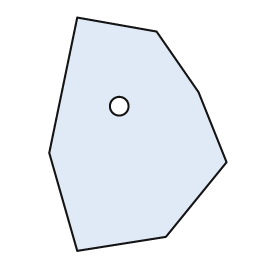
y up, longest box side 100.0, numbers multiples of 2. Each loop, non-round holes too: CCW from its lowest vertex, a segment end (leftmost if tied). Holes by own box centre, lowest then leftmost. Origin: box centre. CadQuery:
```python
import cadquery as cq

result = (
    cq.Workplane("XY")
    .moveTo(-26.0, -50.0)
    .lineTo(12.0, -44.0)
    .lineTo(38.0, -12.0)
    .lineTo(26.0, 18.0)
    .lineTo(8.0, 44.0)
    .lineTo(-26.0, 50.0)
    .lineTo(-38.0, -8.0)
    .close()
    .moveTo(-8.0, 12.0)
    .circle(4.0)
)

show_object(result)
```